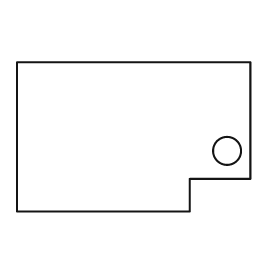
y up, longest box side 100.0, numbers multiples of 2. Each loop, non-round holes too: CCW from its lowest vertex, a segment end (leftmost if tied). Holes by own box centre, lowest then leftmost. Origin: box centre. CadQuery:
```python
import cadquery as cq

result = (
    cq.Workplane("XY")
    .moveTo(-50.0, -32.0)
    .lineTo(24.0, -32.0)
    .lineTo(24.0, -18.0)
    .lineTo(50.0, -18.0)
    .lineTo(50.0, 32.0)
    .lineTo(-50.0, 32.0)
    .close()
    .moveTo(40.0, -6.0)
    .circle(6.0)
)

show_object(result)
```